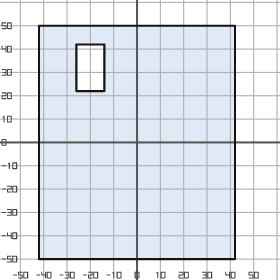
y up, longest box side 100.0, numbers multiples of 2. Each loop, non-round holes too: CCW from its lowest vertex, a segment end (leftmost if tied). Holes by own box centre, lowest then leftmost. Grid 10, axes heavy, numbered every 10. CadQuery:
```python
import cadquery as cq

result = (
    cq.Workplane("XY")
    .moveTo(-42.0, -50.0)
    .lineTo(42.0, -50.0)
    .lineTo(42.0, 50.0)
    .lineTo(-42.0, 50.0)
    .close()
    .moveTo(-26.0, 22.0)
    .lineTo(-14.0, 22.0)
    .lineTo(-14.0, 42.0)
    .lineTo(-26.0, 42.0)
    .close()
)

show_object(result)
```